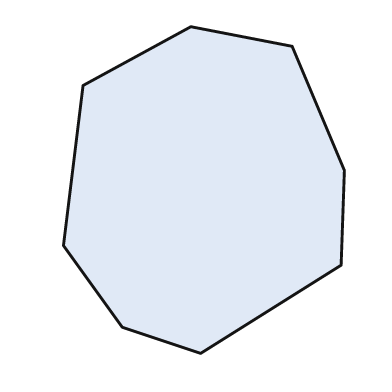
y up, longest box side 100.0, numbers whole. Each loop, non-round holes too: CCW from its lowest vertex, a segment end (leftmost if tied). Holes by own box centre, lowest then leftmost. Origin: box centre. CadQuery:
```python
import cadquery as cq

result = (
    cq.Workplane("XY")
    .moveTo(-1.0, -50.0)
    .lineTo(42.0, -23.0)
    .lineTo(43.0, 6.0)
    .lineTo(27.0, 44.0)
    .lineTo(-4.0, 50.0)
    .lineTo(-37.0, 32.0)
    .lineTo(-43.0, -17.0)
    .lineTo(-25.0, -42.0)
    .close()
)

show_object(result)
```